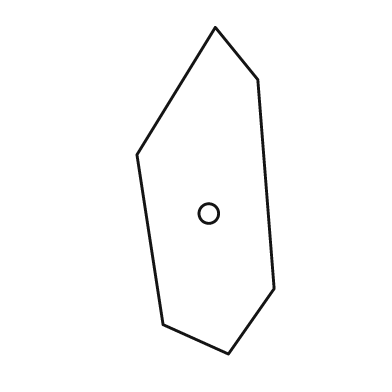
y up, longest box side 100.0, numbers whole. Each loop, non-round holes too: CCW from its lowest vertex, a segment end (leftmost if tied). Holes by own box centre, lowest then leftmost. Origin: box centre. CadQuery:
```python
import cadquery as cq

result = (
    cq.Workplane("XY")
    .moveTo(7.0, -50.0)
    .lineTo(21.0, -30.0)
    .lineTo(16.0, 34.0)
    .lineTo(3.0, 50.0)
    .lineTo(-21.0, 11.0)
    .lineTo(-13.0, -41.0)
    .close()
    .moveTo(1.0, -7.0)
    .circle(3.0)
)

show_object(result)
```